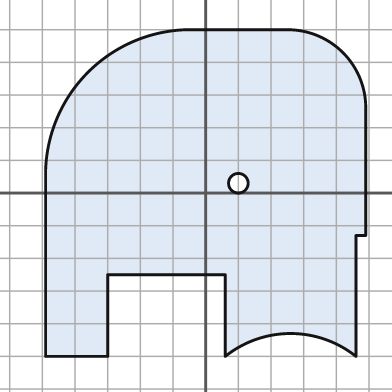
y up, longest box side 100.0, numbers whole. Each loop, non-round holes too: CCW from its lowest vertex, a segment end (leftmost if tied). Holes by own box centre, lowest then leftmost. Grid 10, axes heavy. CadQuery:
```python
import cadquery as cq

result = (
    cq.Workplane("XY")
    .moveTo(-49.0, -50.0)
    .lineTo(-30.0, -50.0)
    .lineTo(-30.0, -25.0)
    .lineTo(6.0, -25.0)
    .lineTo(6.0, -50.0)
    .threePointArc((26.0, -43.0), (46.0, -50.0))
    .lineTo(46.0, -13.0)
    .lineTo(49.0, -13.0)
    .lineTo(49.0, 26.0)
    .threePointArc((42.0, 43.0), (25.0, 50.0))
    .lineTo(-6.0, 50.0)
    .threePointArc((-36.0, 37.0), (-49.0, 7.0))
    .close()
    .moveTo(10.0, 3.0)
    .circle(3.0)
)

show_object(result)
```